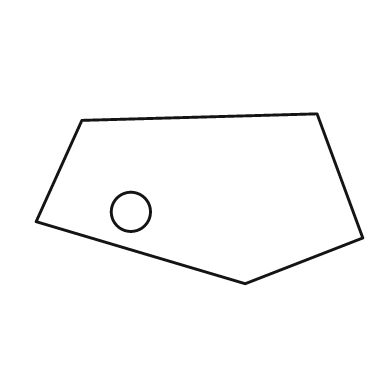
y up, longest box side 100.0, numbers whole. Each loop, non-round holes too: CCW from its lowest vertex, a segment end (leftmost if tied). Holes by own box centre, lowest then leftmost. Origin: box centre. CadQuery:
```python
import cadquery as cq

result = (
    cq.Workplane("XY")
    .moveTo(14.0, -26.0)
    .lineTo(50.0, -12.0)
    .lineTo(36.0, 26.0)
    .lineTo(-36.0, 24.0)
    .lineTo(-50.0, -7.0)
    .close()
    .moveTo(-21.0, -4.0)
    .circle(6.0)
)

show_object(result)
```